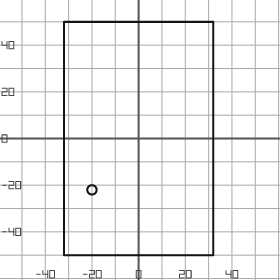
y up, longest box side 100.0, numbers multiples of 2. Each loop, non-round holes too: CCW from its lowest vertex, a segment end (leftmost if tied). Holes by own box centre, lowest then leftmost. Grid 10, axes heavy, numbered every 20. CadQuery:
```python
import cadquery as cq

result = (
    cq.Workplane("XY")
    .moveTo(-32.0, -50.0)
    .lineTo(32.0, -50.0)
    .lineTo(32.0, 50.0)
    .lineTo(-32.0, 50.0)
    .close()
    .moveTo(-20.0, -22.0)
    .circle(2.0)
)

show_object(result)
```